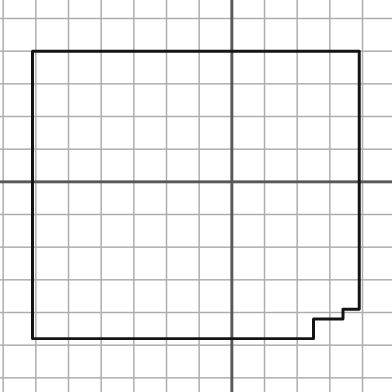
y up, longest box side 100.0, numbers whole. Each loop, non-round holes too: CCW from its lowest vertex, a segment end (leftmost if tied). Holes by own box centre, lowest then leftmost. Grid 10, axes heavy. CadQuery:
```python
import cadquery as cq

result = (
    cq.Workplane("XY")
    .moveTo(-61.0, -48.0)
    .lineTo(25.0, -48.0)
    .lineTo(25.0, -42.0)
    .lineTo(34.0, -42.0)
    .lineTo(34.0, -39.0)
    .lineTo(39.0, -39.0)
    .lineTo(39.0, 40.0)
    .lineTo(-61.0, 40.0)
    .close()
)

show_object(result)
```